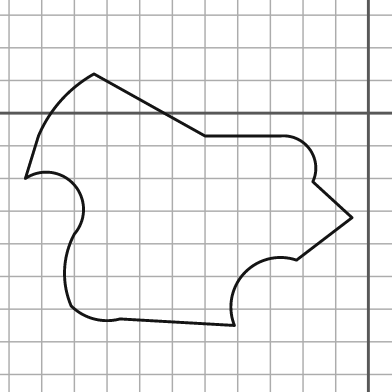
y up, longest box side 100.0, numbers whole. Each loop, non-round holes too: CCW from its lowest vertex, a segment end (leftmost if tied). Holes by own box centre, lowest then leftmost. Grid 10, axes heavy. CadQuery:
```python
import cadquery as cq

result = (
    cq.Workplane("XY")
    .moveTo(-41.0, -65.0)
    .threePointArc((-38.0, -49.0), (-22.0, -45.0))
    .lineTo(-5.0, -32.0)
    .lineTo(-17.0, -21.0)
    .threePointArc((-18.0, -11.0), (-27.0, -7.0))
    .lineTo(-50.0, -7.0)
    .lineTo(-84.0, 12.0)
    .threePointArc((-94.0, 4.0), (-101.0, -7.0))
    .lineTo(-105.0, -20.0)
    .threePointArc((-90.0, -22.0), (-90.0, -37.0))
    .threePointArc((-93.0, -48.0), (-91.0, -59.0))
    .threePointArc((-84.0, -63.0), (-76.0, -63.0))
    .close()
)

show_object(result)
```